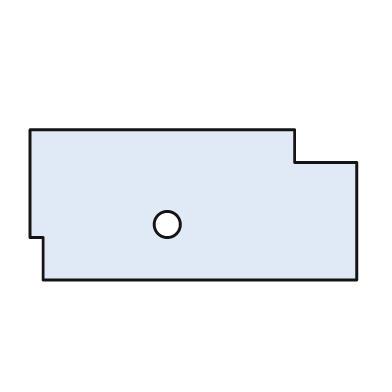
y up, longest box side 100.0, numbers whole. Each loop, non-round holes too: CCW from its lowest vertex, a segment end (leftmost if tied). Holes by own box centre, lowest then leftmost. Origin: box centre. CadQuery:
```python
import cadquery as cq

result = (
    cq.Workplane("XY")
    .moveTo(-46.0, -23.0)
    .lineTo(50.0, -23.0)
    .lineTo(50.0, 13.0)
    .lineTo(31.0, 13.0)
    .lineTo(31.0, 23.0)
    .lineTo(-50.0, 23.0)
    .lineTo(-50.0, -10.0)
    .lineTo(-46.0, -10.0)
    .close()
    .moveTo(-8.0, -6.0)
    .circle(4.0)
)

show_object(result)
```